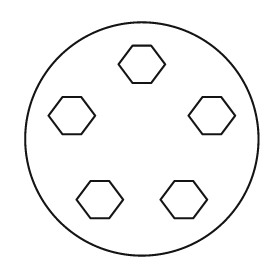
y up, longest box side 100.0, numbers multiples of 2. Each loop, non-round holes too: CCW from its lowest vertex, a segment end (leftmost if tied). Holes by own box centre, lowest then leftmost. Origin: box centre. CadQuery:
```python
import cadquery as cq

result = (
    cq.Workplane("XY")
    .moveTo(0.0, 0.0)
    .circle(50.0)
    .moveTo(-22.0, -34.0)
    .lineTo(-14.0, -34.0)
    .lineTo(-8.0, -26.0)
    .lineTo(-14.0, -18.0)
    .lineTo(-22.0, -18.0)
    .lineTo(-28.0, -26.0)
    .close()
    .moveTo(14.0, -34.0)
    .lineTo(22.0, -34.0)
    .lineTo(28.0, -26.0)
    .lineTo(22.0, -18.0)
    .lineTo(14.0, -18.0)
    .lineTo(8.0, -26.0)
    .close()
    .moveTo(-34.0, 2.0)
    .lineTo(-26.0, 2.0)
    .lineTo(-20.0, 10.0)
    .lineTo(-26.0, 18.0)
    .lineTo(-34.0, 18.0)
    .lineTo(-40.0, 10.0)
    .close()
    .moveTo(26.0, 2.0)
    .lineTo(34.0, 2.0)
    .lineTo(40.0, 10.0)
    .lineTo(34.0, 18.0)
    .lineTo(26.0, 18.0)
    .lineTo(20.0, 10.0)
    .close()
    .moveTo(-4.0, 24.0)
    .lineTo(4.0, 24.0)
    .lineTo(10.0, 32.0)
    .lineTo(4.0, 40.0)
    .lineTo(-4.0, 40.0)
    .lineTo(-10.0, 32.0)
    .close()
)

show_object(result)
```